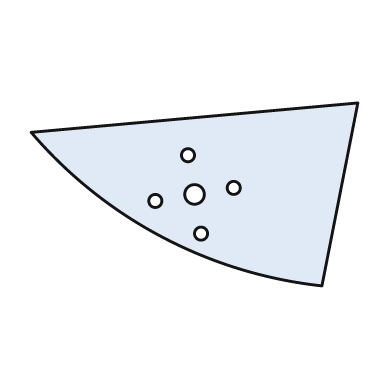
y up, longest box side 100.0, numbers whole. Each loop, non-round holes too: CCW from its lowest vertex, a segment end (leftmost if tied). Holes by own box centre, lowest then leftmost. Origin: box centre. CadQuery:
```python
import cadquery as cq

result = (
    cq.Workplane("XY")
    .moveTo(39.0, -28.0)
    .lineTo(50.0, 28.0)
    .lineTo(-50.0, 19.0)
    .threePointArc((-10.0, -13.0), (39.0, -28.0))
    .close()
    .moveTo(2.0, -12.0)
    .circle(2.0)
    .moveTo(-12.0, -2.0)
    .circle(2.0)
    .moveTo(0.0, 0.0)
    .circle(3.0)
    .moveTo(12.0, 2.0)
    .circle(2.0)
    .moveTo(-2.0, 12.0)
    .circle(2.0)
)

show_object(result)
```